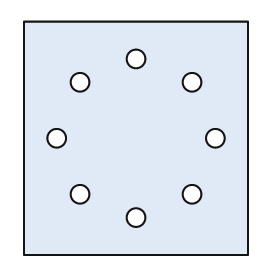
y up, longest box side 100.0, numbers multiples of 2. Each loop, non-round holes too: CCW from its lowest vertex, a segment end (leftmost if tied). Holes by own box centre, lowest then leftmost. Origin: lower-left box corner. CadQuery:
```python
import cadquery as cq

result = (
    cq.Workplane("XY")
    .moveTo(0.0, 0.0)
    .lineTo(96.0, 0.0)
    .lineTo(96.0, 100.0)
    .lineTo(0.0, 100.0)
    .close()
    .moveTo(48.0, 16.0)
    .circle(4.0)
    .moveTo(24.0, 26.0)
    .circle(4.0)
    .moveTo(72.0, 26.0)
    .circle(4.0)
    .moveTo(14.0, 50.0)
    .circle(4.0)
    .moveTo(82.0, 50.0)
    .circle(4.0)
    .moveTo(24.0, 74.0)
    .circle(4.0)
    .moveTo(72.0, 74.0)
    .circle(4.0)
    .moveTo(48.0, 84.0)
    .circle(4.0)
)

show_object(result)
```